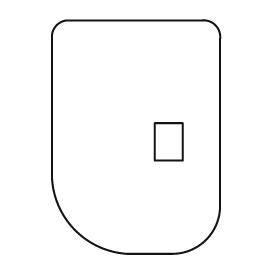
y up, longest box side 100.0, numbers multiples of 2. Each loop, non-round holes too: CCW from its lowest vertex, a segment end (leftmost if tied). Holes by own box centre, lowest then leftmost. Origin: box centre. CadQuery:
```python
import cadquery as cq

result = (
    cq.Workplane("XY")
    .moveTo(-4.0, -50.0)
    .lineTo(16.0, -50.0)
    .threePointArc((30.0, -44.0), (36.0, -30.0))
    .lineTo(36.0, 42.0)
    .threePointArc((34.0, 48.0), (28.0, 50.0))
    .lineTo(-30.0, 50.0)
    .threePointArc((-34.0, 48.0), (-36.0, 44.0))
    .lineTo(-36.0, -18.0)
    .threePointArc((-26.0, -40.0), (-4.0, -50.0))
    .close()
    .moveTo(8.0, -10.0)
    .lineTo(20.0, -10.0)
    .lineTo(20.0, 6.0)
    .lineTo(8.0, 6.0)
    .close()
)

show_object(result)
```